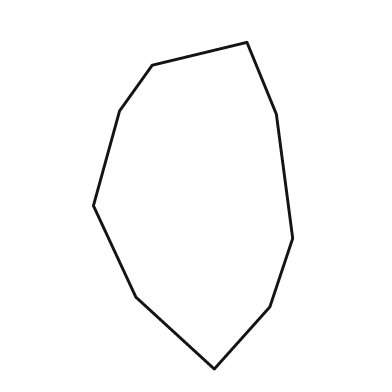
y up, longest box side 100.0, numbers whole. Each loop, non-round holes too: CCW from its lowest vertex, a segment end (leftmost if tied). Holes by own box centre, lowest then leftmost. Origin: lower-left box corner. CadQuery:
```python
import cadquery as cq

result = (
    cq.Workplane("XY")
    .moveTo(37.0, 0.0)
    .lineTo(54.0, 19.0)
    .lineTo(61.0, 40.0)
    .lineTo(56.0, 78.0)
    .lineTo(47.0, 100.0)
    .lineTo(18.0, 93.0)
    .lineTo(8.0, 79.0)
    .lineTo(0.0, 50.0)
    .lineTo(13.0, 22.0)
    .close()
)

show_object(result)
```